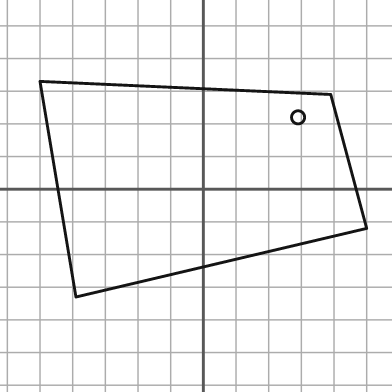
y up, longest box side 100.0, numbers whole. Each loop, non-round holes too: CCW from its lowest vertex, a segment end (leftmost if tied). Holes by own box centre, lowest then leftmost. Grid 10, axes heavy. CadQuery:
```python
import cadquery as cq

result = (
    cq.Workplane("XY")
    .moveTo(-39.0, -33.0)
    .lineTo(50.0, -12.0)
    .lineTo(39.0, 29.0)
    .lineTo(-50.0, 33.0)
    .close()
    .moveTo(29.0, 22.0)
    .circle(2.0)
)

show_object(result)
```